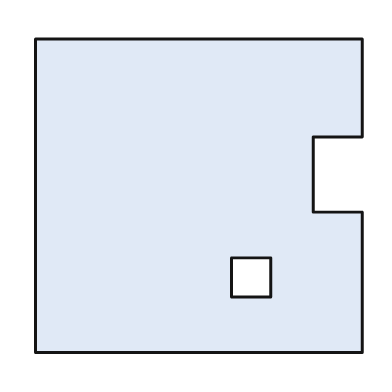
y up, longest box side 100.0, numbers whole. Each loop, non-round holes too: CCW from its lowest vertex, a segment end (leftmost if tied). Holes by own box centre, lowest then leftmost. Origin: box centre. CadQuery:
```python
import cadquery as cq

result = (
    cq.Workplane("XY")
    .moveTo(-50.0, -48.0)
    .lineTo(50.0, -48.0)
    .lineTo(50.0, -5.0)
    .lineTo(35.0, -5.0)
    .lineTo(35.0, 18.0)
    .lineTo(50.0, 18.0)
    .lineTo(50.0, 48.0)
    .lineTo(-50.0, 48.0)
    .close()
    .moveTo(10.0, -31.0)
    .lineTo(22.0, -31.0)
    .lineTo(22.0, -19.0)
    .lineTo(10.0, -19.0)
    .close()
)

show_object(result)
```